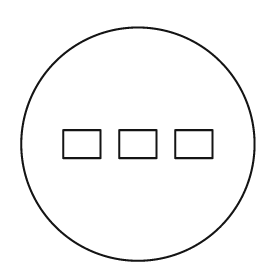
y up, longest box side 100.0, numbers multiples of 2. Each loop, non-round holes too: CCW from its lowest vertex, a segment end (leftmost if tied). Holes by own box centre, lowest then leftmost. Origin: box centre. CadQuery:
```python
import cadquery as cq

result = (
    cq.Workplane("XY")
    .moveTo(0.0, 0.0)
    .circle(50.0)
    .moveTo(-32.0, -6.0)
    .lineTo(-16.0, -6.0)
    .lineTo(-16.0, 6.0)
    .lineTo(-32.0, 6.0)
    .close()
    .moveTo(-8.0, -6.0)
    .lineTo(8.0, -6.0)
    .lineTo(8.0, 6.0)
    .lineTo(-8.0, 6.0)
    .close()
    .moveTo(16.0, -6.0)
    .lineTo(32.0, -6.0)
    .lineTo(32.0, 6.0)
    .lineTo(16.0, 6.0)
    .close()
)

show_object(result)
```